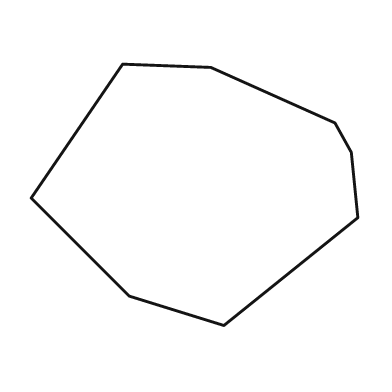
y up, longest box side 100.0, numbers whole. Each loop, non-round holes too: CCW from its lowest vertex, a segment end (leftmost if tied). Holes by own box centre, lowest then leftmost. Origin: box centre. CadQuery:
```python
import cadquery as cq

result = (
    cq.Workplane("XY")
    .moveTo(9.0, -40.0)
    .lineTo(50.0, -7.0)
    .lineTo(48.0, 13.0)
    .lineTo(43.0, 22.0)
    .lineTo(5.0, 39.0)
    .lineTo(-22.0, 40.0)
    .lineTo(-50.0, -1.0)
    .lineTo(-20.0, -31.0)
    .close()
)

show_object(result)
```